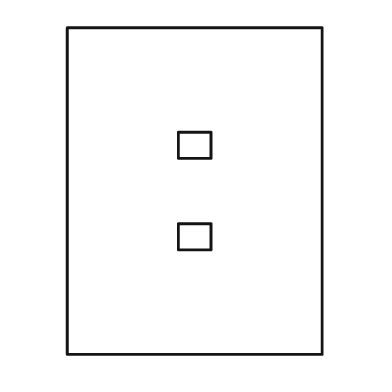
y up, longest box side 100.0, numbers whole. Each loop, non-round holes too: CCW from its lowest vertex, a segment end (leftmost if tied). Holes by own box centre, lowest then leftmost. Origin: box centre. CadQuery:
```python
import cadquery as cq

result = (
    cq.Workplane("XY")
    .moveTo(-39.0, -50.0)
    .lineTo(39.0, -50.0)
    .lineTo(39.0, 50.0)
    .lineTo(-39.0, 50.0)
    .close()
    .moveTo(-5.0, -18.0)
    .lineTo(5.0, -18.0)
    .lineTo(5.0, -10.0)
    .lineTo(-5.0, -10.0)
    .close()
    .moveTo(-5.0, 10.0)
    .lineTo(5.0, 10.0)
    .lineTo(5.0, 18.0)
    .lineTo(-5.0, 18.0)
    .close()
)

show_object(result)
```